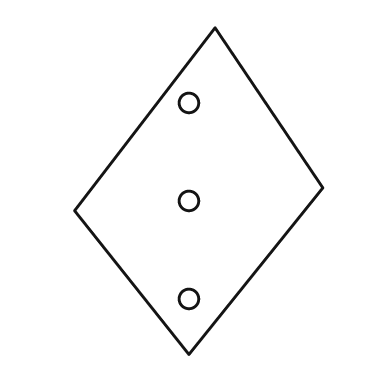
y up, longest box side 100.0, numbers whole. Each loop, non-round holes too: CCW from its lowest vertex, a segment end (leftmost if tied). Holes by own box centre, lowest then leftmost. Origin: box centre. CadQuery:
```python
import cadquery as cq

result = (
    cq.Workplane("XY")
    .moveTo(-3.0, -50.0)
    .lineTo(38.0, 1.0)
    .lineTo(5.0, 50.0)
    .lineTo(-38.0, -6.0)
    .close()
    .moveTo(-3.0, -33.0)
    .circle(3.0)
    .moveTo(-3.0, -3.0)
    .circle(3.0)
    .moveTo(-3.0, 27.0)
    .circle(3.0)
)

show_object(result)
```